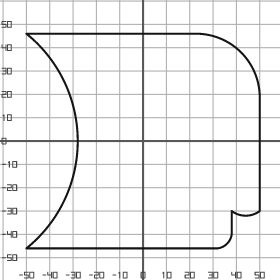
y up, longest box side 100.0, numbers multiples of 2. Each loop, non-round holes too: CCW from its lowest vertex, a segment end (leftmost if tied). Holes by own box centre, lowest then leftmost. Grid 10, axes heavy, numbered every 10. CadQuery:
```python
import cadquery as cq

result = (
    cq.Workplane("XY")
    .moveTo(-50.0, -46.0)
    .lineTo(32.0, -46.0)
    .threePointArc((36.0, -44.0), (38.0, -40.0))
    .lineTo(38.0, -30.0)
    .threePointArc((44.0, -32.0), (50.0, -30.0))
    .lineTo(50.0, 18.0)
    .threePointArc((42.0, 38.0), (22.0, 46.0))
    .lineTo(-50.0, 46.0)
    .threePointArc((-28.0, 0.0), (-50.0, -46.0))
    .close()
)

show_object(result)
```